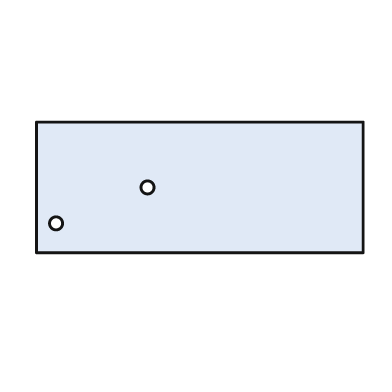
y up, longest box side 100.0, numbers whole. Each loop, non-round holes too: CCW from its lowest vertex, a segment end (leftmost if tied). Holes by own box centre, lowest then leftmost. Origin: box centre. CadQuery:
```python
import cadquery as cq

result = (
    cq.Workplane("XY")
    .moveTo(-50.0, -20.0)
    .lineTo(50.0, -20.0)
    .lineTo(50.0, 20.0)
    .lineTo(-50.0, 20.0)
    .close()
    .moveTo(-44.0, -11.0)
    .circle(2.0)
    .moveTo(-16.0, 0.0)
    .circle(2.0)
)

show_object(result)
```